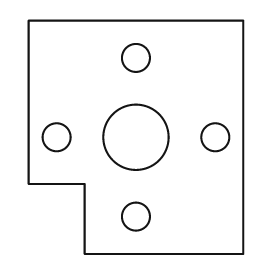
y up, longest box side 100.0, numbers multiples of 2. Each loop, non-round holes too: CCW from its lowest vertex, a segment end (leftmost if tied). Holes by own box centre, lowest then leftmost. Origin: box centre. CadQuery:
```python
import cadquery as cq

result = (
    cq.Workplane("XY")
    .moveTo(-22.0, -50.0)
    .lineTo(46.0, -50.0)
    .lineTo(46.0, 50.0)
    .lineTo(-46.0, 50.0)
    .lineTo(-46.0, -20.0)
    .lineTo(-22.0, -20.0)
    .close()
    .moveTo(0.0, -34.0)
    .circle(6.0)
    .moveTo(-34.0, 0.0)
    .circle(6.0)
    .moveTo(0.0, 0.0)
    .circle(14.0)
    .moveTo(34.0, 0.0)
    .circle(6.0)
    .moveTo(0.0, 34.0)
    .circle(6.0)
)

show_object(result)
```